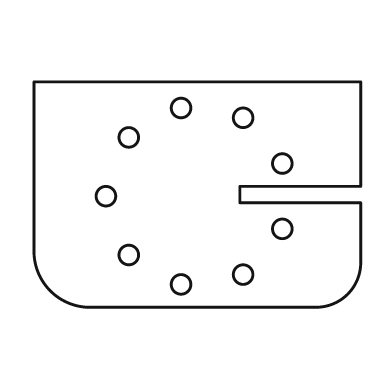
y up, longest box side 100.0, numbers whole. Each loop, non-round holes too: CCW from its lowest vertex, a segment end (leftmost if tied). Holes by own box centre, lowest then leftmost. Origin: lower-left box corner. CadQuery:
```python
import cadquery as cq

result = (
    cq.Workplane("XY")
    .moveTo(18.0, 0.0)
    .lineTo(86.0, 0.0)
    .threePointArc((96.0, 4.0), (100.0, 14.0))
    .lineTo(100.0, 32.0)
    .lineTo(63.0, 32.0)
    .lineTo(63.0, 37.0)
    .lineTo(100.0, 37.0)
    .lineTo(100.0, 69.0)
    .lineTo(0.0, 69.0)
    .lineTo(0.0, 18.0)
    .threePointArc((5.0, 5.0), (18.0, 0.0))
    .close()
    .moveTo(45.0, 7.0)
    .circle(3.0)
    .moveTo(64.0, 10.0)
    .circle(3.0)
    .moveTo(29.0, 16.0)
    .circle(3.0)
    .moveTo(76.0, 24.0)
    .circle(3.0)
    .moveTo(22.0, 34.0)
    .circle(3.0)
    .moveTo(76.0, 44.0)
    .circle(3.0)
    .moveTo(29.0, 52.0)
    .circle(3.0)
    .moveTo(64.0, 58.0)
    .circle(3.0)
    .moveTo(45.0, 61.0)
    .circle(3.0)
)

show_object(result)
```